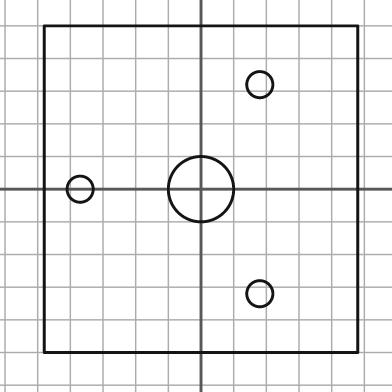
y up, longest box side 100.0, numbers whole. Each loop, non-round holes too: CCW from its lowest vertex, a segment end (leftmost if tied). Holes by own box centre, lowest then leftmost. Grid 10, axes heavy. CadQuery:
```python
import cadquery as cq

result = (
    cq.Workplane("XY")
    .moveTo(-48.0, -50.0)
    .lineTo(48.0, -50.0)
    .lineTo(48.0, 50.0)
    .lineTo(-48.0, 50.0)
    .close()
    .moveTo(18.0, -32.0)
    .circle(4.0)
    .moveTo(-37.0, 0.0)
    .circle(4.0)
    .moveTo(0.0, 0.0)
    .circle(10.0)
    .moveTo(18.0, 32.0)
    .circle(4.0)
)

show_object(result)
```